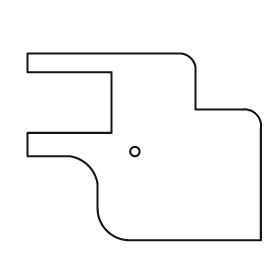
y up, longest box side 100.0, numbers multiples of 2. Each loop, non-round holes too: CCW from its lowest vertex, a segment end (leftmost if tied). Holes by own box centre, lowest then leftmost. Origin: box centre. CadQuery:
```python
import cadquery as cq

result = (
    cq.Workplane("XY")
    .moveTo(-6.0, -40.0)
    .lineTo(50.0, -40.0)
    .lineTo(50.0, 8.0)
    .threePointArc((48.0, 14.0), (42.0, 16.0))
    .lineTo(22.0, 16.0)
    .lineTo(22.0, 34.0)
    .threePointArc((20.0, 38.0), (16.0, 40.0))
    .lineTo(-50.0, 40.0)
    .lineTo(-50.0, 32.0)
    .lineTo(-14.0, 32.0)
    .lineTo(-14.0, 6.0)
    .lineTo(-50.0, 6.0)
    .lineTo(-50.0, -4.0)
    .lineTo(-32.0, -4.0)
    .threePointArc((-24.0, -8.0), (-20.0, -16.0))
    .lineTo(-20.0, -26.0)
    .threePointArc((-16.0, -36.0), (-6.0, -40.0))
    .close()
    .moveTo(-4.0, -2.0)
    .circle(2.0)
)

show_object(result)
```